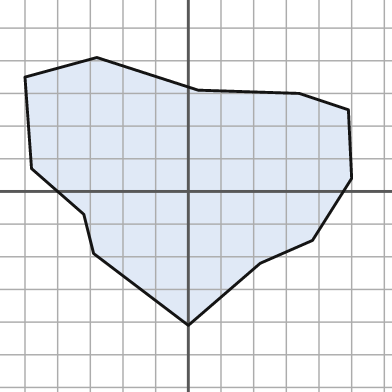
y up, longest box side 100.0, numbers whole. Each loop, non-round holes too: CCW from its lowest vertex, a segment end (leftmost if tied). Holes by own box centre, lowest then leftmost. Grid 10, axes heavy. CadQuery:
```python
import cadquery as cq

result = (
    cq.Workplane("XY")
    .moveTo(0.0, -41.0)
    .lineTo(22.0, -22.0)
    .lineTo(38.0, -15.0)
    .lineTo(50.0, 4.0)
    .lineTo(49.0, 25.0)
    .lineTo(34.0, 30.0)
    .lineTo(3.0, 31.0)
    .lineTo(-28.0, 41.0)
    .lineTo(-50.0, 35.0)
    .lineTo(-48.0, 7.0)
    .lineTo(-32.0, -7.0)
    .lineTo(-29.0, -19.0)
    .close()
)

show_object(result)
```